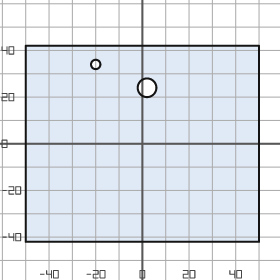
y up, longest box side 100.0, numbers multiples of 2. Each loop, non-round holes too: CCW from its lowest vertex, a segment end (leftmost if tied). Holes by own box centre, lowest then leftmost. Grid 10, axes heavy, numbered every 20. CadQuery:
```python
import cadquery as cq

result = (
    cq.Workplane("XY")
    .moveTo(-50.0, -42.0)
    .lineTo(50.0, -42.0)
    .lineTo(50.0, 42.0)
    .lineTo(-50.0, 42.0)
    .close()
    .moveTo(2.0, 24.0)
    .circle(4.0)
    .moveTo(-20.0, 34.0)
    .circle(2.0)
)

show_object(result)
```